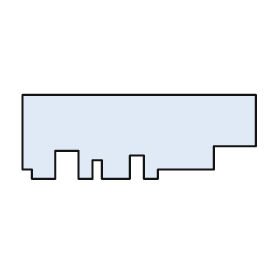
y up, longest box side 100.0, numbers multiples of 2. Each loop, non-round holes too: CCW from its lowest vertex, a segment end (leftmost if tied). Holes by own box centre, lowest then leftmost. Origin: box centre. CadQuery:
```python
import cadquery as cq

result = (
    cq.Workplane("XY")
    .moveTo(-46.0, -18.0)
    .lineTo(-36.0, -18.0)
    .lineTo(-36.0, -6.0)
    .lineTo(-26.0, -6.0)
    .lineTo(-26.0, -18.0)
    .lineTo(-20.0, -18.0)
    .lineTo(-20.0, -10.0)
    .lineTo(-16.0, -10.0)
    .lineTo(-16.0, -18.0)
    .lineTo(-4.0, -18.0)
    .lineTo(-4.0, -8.0)
    .lineTo(2.0, -8.0)
    .lineTo(2.0, -18.0)
    .lineTo(8.0, -18.0)
    .lineTo(8.0, -14.0)
    .lineTo(32.0, -14.0)
    .lineTo(32.0, -4.0)
    .lineTo(50.0, -4.0)
    .lineTo(50.0, 18.0)
    .lineTo(-50.0, 18.0)
    .lineTo(-50.0, -14.0)
    .lineTo(-46.0, -14.0)
    .close()
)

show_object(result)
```